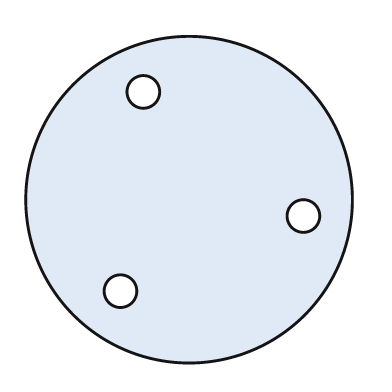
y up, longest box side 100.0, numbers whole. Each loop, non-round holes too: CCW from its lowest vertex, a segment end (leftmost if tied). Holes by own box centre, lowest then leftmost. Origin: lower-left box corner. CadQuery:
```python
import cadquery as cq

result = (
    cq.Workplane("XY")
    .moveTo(50.0, 50.0)
    .circle(50.0)
    .moveTo(29.0, 22.0)
    .circle(5.0)
    .moveTo(85.0, 45.0)
    .circle(5.0)
    .moveTo(36.0, 83.0)
    .circle(5.0)
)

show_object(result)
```